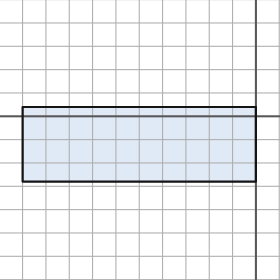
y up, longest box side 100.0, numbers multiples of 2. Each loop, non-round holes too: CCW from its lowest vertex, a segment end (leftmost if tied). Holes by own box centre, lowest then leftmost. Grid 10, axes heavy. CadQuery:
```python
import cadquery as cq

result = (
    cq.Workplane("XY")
    .moveTo(-100.0, -28.0)
    .lineTo(0.0, -28.0)
    .lineTo(0.0, 4.0)
    .lineTo(-100.0, 4.0)
    .close()
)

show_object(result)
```